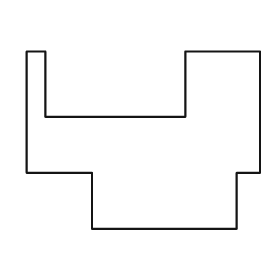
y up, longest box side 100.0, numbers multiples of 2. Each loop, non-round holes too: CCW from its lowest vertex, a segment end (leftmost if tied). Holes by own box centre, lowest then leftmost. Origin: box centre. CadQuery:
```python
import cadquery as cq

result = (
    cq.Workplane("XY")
    .moveTo(-22.0, -38.0)
    .lineTo(40.0, -38.0)
    .lineTo(40.0, -14.0)
    .lineTo(50.0, -14.0)
    .lineTo(50.0, 38.0)
    .lineTo(18.0, 38.0)
    .lineTo(18.0, 10.0)
    .lineTo(-42.0, 10.0)
    .lineTo(-42.0, 38.0)
    .lineTo(-50.0, 38.0)
    .lineTo(-50.0, -14.0)
    .lineTo(-22.0, -14.0)
    .close()
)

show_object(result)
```